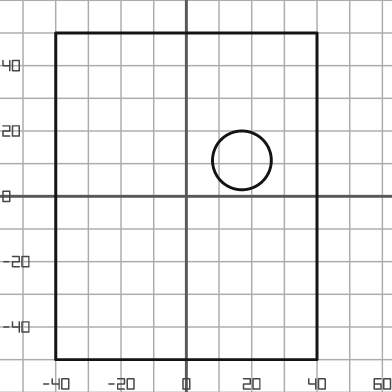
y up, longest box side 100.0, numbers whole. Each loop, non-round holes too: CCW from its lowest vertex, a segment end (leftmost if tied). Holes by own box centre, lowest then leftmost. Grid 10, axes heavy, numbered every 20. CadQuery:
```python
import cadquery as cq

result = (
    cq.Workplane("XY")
    .moveTo(-40.0, -50.0)
    .lineTo(40.0, -50.0)
    .lineTo(40.0, 50.0)
    .lineTo(-40.0, 50.0)
    .close()
    .moveTo(17.0, 11.0)
    .circle(9.0)
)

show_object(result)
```